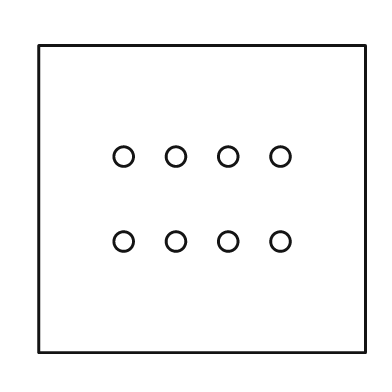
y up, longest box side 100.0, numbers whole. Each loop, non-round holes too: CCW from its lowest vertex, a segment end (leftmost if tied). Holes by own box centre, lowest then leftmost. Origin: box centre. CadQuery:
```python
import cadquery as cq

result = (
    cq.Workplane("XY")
    .moveTo(-50.0, -47.0)
    .lineTo(50.0, -47.0)
    .lineTo(50.0, 47.0)
    .lineTo(-50.0, 47.0)
    .close()
    .moveTo(-24.0, -13.0)
    .circle(3.0)
    .moveTo(-8.0, -13.0)
    .circle(3.0)
    .moveTo(8.0, -13.0)
    .circle(3.0)
    .moveTo(24.0, -13.0)
    .circle(3.0)
    .moveTo(-24.0, 13.0)
    .circle(3.0)
    .moveTo(-8.0, 13.0)
    .circle(3.0)
    .moveTo(8.0, 13.0)
    .circle(3.0)
    .moveTo(24.0, 13.0)
    .circle(3.0)
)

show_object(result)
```